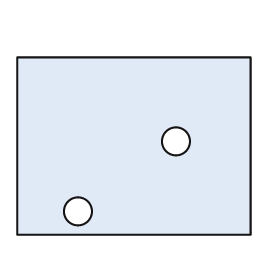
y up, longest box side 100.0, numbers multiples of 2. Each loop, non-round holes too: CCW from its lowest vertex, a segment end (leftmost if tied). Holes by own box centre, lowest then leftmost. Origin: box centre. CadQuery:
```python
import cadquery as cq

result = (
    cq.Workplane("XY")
    .moveTo(-50.0, -38.0)
    .lineTo(50.0, -38.0)
    .lineTo(50.0, 38.0)
    .lineTo(-50.0, 38.0)
    .close()
    .moveTo(-24.0, -28.0)
    .circle(6.0)
    .moveTo(18.0, 2.0)
    .circle(6.0)
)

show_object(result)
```